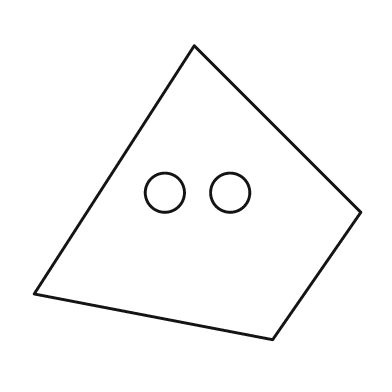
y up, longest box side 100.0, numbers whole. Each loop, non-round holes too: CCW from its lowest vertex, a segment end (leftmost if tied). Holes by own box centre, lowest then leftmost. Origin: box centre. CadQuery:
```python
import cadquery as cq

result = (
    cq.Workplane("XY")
    .moveTo(23.0, -45.0)
    .lineTo(50.0, -6.0)
    .lineTo(-1.0, 45.0)
    .lineTo(-50.0, -31.0)
    .close()
    .moveTo(-10.0, 0.0)
    .circle(6.0)
    .moveTo(10.0, 0.0)
    .circle(6.0)
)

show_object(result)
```